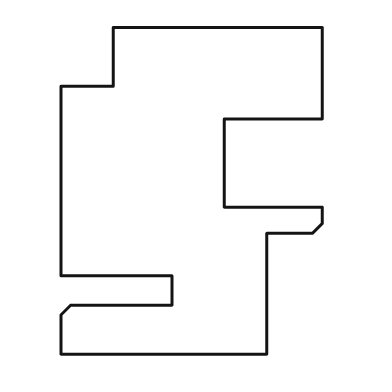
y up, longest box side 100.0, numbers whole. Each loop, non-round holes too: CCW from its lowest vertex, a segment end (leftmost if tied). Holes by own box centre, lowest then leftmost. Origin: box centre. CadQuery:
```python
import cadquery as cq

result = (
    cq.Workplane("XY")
    .moveTo(-40.0, -50.0)
    .lineTo(23.0, -50.0)
    .lineTo(23.0, -13.0)
    .lineTo(37.0, -13.0)
    .lineTo(40.0, -10.0)
    .lineTo(40.0, -5.0)
    .lineTo(10.0, -5.0)
    .lineTo(10.0, 22.0)
    .lineTo(40.0, 22.0)
    .lineTo(40.0, 50.0)
    .lineTo(-24.0, 50.0)
    .lineTo(-24.0, 32.0)
    .lineTo(-40.0, 32.0)
    .lineTo(-40.0, -26.0)
    .lineTo(-6.0, -26.0)
    .lineTo(-6.0, -35.0)
    .lineTo(-37.0, -35.0)
    .lineTo(-40.0, -38.0)
    .close()
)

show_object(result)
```